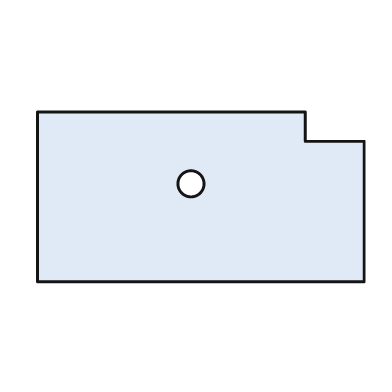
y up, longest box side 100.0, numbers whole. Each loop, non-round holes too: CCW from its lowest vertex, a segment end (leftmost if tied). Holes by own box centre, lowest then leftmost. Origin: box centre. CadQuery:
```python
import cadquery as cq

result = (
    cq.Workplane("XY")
    .moveTo(-50.0, -26.0)
    .lineTo(50.0, -26.0)
    .lineTo(50.0, 17.0)
    .lineTo(32.0, 17.0)
    .lineTo(32.0, 26.0)
    .lineTo(-50.0, 26.0)
    .close()
    .moveTo(-3.0, 4.0)
    .circle(4.0)
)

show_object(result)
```